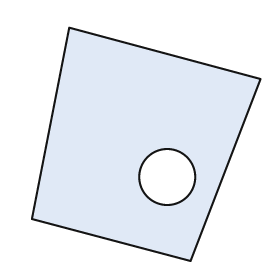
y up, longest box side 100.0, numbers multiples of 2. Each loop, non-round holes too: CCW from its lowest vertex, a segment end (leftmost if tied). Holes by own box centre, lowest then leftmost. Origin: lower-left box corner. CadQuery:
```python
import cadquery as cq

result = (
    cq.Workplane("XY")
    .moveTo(68.0, 0.0)
    .lineTo(98.0, 78.0)
    .lineTo(16.0, 100.0)
    .lineTo(0.0, 18.0)
    .close()
    .moveTo(58.0, 36.0)
    .circle(12.0)
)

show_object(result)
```